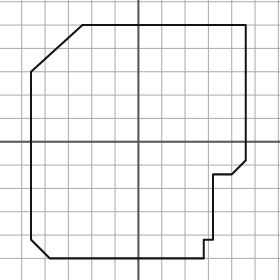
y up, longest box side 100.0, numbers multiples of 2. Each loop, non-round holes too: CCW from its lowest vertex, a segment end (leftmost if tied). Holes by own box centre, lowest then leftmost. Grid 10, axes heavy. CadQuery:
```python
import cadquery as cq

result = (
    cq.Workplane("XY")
    .moveTo(-38.0, -50.0)
    .lineTo(28.0, -50.0)
    .lineTo(28.0, -42.0)
    .lineTo(32.0, -42.0)
    .lineTo(32.0, -14.0)
    .lineTo(40.0, -14.0)
    .lineTo(46.0, -8.0)
    .lineTo(46.0, 50.0)
    .lineTo(-24.0, 50.0)
    .lineTo(-46.0, 30.0)
    .lineTo(-46.0, -42.0)
    .close()
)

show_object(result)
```